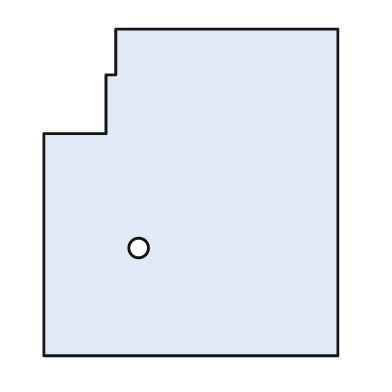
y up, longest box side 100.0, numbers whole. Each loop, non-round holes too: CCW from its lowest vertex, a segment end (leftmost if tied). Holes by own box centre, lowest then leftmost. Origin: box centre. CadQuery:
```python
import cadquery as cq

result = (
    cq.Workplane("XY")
    .moveTo(-45.0, -50.0)
    .lineTo(45.0, -50.0)
    .lineTo(45.0, 50.0)
    .lineTo(-23.0, 50.0)
    .lineTo(-23.0, 36.0)
    .lineTo(-26.0, 36.0)
    .lineTo(-26.0, 18.0)
    .lineTo(-45.0, 18.0)
    .close()
    .moveTo(-16.0, -17.0)
    .circle(3.0)
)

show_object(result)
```